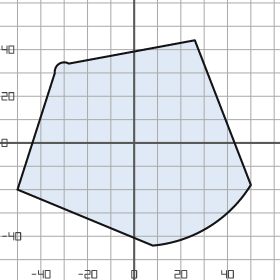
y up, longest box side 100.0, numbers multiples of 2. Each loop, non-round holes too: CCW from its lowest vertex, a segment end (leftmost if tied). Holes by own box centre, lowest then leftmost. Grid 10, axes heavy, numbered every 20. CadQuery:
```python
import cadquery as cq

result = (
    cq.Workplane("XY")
    .moveTo(8.0, -44.0)
    .threePointArc((32.0, -36.0), (50.0, -18.0))
    .lineTo(26.0, 44.0)
    .lineTo(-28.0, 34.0)
    .threePointArc((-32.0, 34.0), (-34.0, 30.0))
    .lineTo(-50.0, -20.0)
    .close()
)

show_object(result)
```